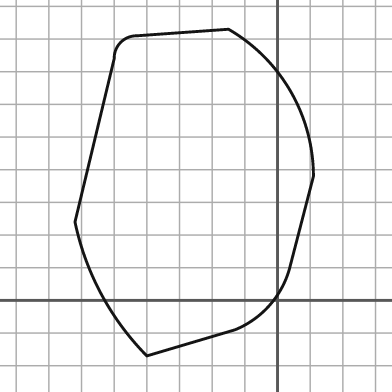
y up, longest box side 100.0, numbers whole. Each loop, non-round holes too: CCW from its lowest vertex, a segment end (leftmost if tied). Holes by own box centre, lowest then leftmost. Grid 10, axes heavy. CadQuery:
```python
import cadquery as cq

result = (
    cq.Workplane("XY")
    .moveTo(-40.0, -17.0)
    .lineTo(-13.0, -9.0)
    .threePointArc((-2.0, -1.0), (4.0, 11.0))
    .lineTo(11.0, 38.0)
    .threePointArc((4.0, 64.0), (-15.0, 83.0))
    .lineTo(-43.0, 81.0)
    .threePointArc((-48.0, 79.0), (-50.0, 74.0))
    .lineTo(-62.0, 24.0)
    .threePointArc((-54.0, 2.0), (-40.0, -17.0))
    .close()
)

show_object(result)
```